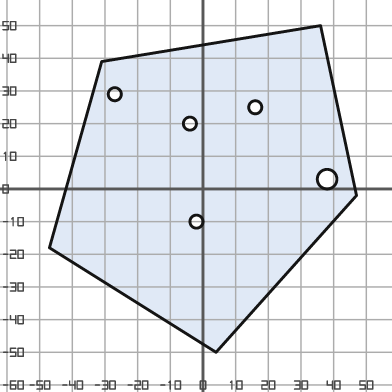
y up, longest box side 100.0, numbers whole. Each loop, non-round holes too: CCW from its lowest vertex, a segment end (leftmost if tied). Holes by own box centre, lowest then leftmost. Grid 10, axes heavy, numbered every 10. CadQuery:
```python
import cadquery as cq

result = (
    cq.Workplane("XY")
    .moveTo(4.0, -50.0)
    .lineTo(47.0, -2.0)
    .lineTo(36.0, 50.0)
    .lineTo(-31.0, 39.0)
    .lineTo(-47.0, -18.0)
    .close()
    .moveTo(-2.0, -10.0)
    .circle(2.0)
    .moveTo(38.0, 3.0)
    .circle(3.0)
    .moveTo(-4.0, 20.0)
    .circle(2.0)
    .moveTo(16.0, 25.0)
    .circle(2.0)
    .moveTo(-27.0, 29.0)
    .circle(2.0)
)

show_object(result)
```